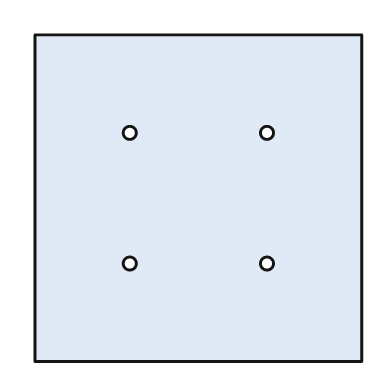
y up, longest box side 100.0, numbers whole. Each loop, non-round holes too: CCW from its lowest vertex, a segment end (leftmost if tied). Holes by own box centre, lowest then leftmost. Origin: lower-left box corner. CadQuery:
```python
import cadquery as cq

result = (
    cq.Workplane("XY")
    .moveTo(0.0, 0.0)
    .lineTo(100.0, 0.0)
    .lineTo(100.0, 100.0)
    .lineTo(0.0, 100.0)
    .close()
    .moveTo(29.0, 30.0)
    .circle(2.0)
    .moveTo(71.0, 30.0)
    .circle(2.0)
    .moveTo(29.0, 70.0)
    .circle(2.0)
    .moveTo(71.0, 70.0)
    .circle(2.0)
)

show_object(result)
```